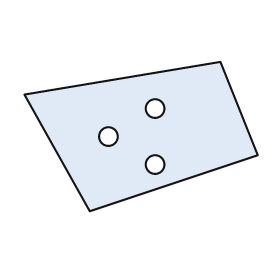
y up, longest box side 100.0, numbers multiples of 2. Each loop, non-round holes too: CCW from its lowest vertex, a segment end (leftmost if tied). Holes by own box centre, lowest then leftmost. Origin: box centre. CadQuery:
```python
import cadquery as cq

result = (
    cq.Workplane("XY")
    .moveTo(-22.0, -32.0)
    .lineTo(50.0, -8.0)
    .lineTo(34.0, 32.0)
    .lineTo(-50.0, 18.0)
    .close()
    .moveTo(6.0, -12.0)
    .circle(4.0)
    .moveTo(-14.0, 0.0)
    .circle(4.0)
    .moveTo(6.0, 12.0)
    .circle(4.0)
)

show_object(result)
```